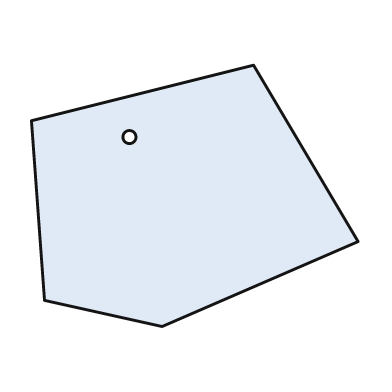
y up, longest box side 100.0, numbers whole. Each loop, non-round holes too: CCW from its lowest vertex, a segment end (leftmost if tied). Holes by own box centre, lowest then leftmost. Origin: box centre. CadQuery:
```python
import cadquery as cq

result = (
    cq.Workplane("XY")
    .moveTo(-10.0, -40.0)
    .lineTo(50.0, -14.0)
    .lineTo(18.0, 40.0)
    .lineTo(-50.0, 23.0)
    .lineTo(-46.0, -32.0)
    .close()
    .moveTo(-20.0, 18.0)
    .circle(2.0)
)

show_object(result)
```